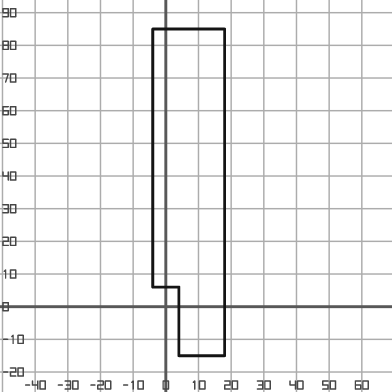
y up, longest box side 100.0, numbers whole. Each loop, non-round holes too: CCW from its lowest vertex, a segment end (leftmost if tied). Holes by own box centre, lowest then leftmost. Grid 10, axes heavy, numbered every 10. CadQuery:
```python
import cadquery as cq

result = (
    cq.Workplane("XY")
    .moveTo(4.0, -15.0)
    .lineTo(18.0, -15.0)
    .lineTo(18.0, 85.0)
    .lineTo(-4.0, 85.0)
    .lineTo(-4.0, 6.0)
    .lineTo(4.0, 6.0)
    .close()
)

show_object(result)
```